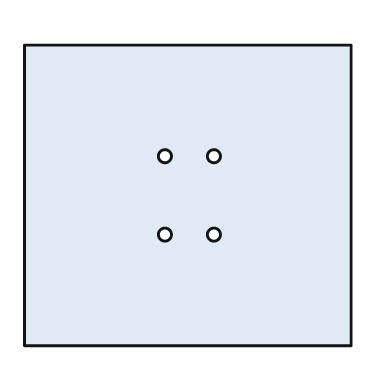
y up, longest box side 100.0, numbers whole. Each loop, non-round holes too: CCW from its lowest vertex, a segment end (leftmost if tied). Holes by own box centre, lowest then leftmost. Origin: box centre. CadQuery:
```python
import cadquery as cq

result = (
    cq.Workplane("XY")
    .moveTo(-50.0, -46.0)
    .lineTo(50.0, -46.0)
    .lineTo(50.0, 46.0)
    .lineTo(-50.0, 46.0)
    .close()
    .moveTo(-7.0, -12.0)
    .circle(2.0)
    .moveTo(8.0, -12.0)
    .circle(2.0)
    .moveTo(-7.0, 12.0)
    .circle(2.0)
    .moveTo(8.0, 12.0)
    .circle(2.0)
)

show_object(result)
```